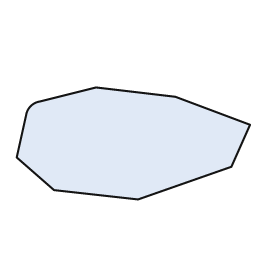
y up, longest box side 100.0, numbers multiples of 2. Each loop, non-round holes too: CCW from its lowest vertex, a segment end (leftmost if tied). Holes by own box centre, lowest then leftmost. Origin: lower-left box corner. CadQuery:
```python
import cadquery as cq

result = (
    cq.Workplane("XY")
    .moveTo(52.0, 0.0)
    .lineTo(92.0, 14.0)
    .lineTo(100.0, 32.0)
    .lineTo(68.0, 44.0)
    .lineTo(34.0, 48.0)
    .lineTo(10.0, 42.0)
    .threePointArc((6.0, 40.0), (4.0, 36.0))
    .lineTo(0.0, 18.0)
    .lineTo(16.0, 4.0)
    .close()
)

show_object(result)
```